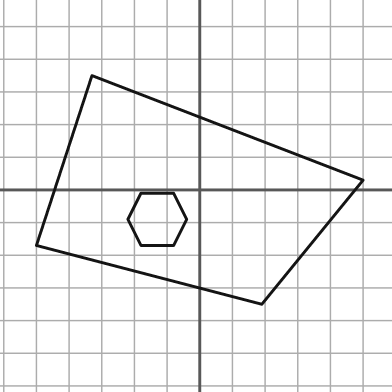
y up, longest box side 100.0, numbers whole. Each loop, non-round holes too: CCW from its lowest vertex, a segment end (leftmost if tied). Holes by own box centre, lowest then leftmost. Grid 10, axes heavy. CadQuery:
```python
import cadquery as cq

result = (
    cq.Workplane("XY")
    .moveTo(19.0, -35.0)
    .lineTo(50.0, 3.0)
    .lineTo(-33.0, 35.0)
    .lineTo(-50.0, -17.0)
    .close()
    .moveTo(-18.0, -17.0)
    .lineTo(-8.0, -17.0)
    .lineTo(-4.0, -9.0)
    .lineTo(-8.0, -1.0)
    .lineTo(-18.0, -1.0)
    .lineTo(-22.0, -9.0)
    .close()
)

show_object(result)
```